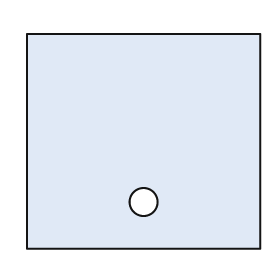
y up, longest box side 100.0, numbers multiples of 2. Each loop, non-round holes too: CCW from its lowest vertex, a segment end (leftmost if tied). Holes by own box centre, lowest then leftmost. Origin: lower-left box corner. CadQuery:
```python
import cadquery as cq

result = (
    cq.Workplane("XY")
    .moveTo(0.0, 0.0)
    .lineTo(100.0, 0.0)
    .lineTo(100.0, 92.0)
    .lineTo(0.0, 92.0)
    .close()
    .moveTo(50.0, 20.0)
    .circle(6.0)
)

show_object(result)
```